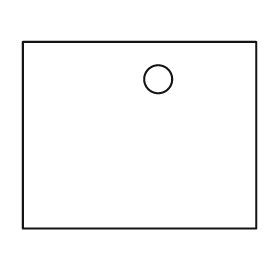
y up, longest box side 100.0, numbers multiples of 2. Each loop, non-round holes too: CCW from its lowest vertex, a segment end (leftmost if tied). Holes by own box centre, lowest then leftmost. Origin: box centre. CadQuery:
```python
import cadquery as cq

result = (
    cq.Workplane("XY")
    .moveTo(-50.0, -40.0)
    .lineTo(50.0, -40.0)
    .lineTo(50.0, 40.0)
    .lineTo(-50.0, 40.0)
    .close()
    .moveTo(8.0, 24.0)
    .circle(6.0)
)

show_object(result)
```